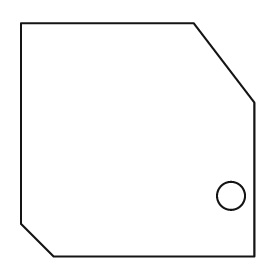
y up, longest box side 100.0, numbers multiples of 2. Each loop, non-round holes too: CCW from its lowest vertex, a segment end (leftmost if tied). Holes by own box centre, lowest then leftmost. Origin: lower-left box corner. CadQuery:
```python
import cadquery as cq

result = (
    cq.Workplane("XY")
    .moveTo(14.0, 0.0)
    .lineTo(100.0, 0.0)
    .lineTo(100.0, 66.0)
    .lineTo(74.0, 100.0)
    .lineTo(0.0, 100.0)
    .lineTo(0.0, 14.0)
    .close()
    .moveTo(90.0, 26.0)
    .circle(6.0)
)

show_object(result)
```